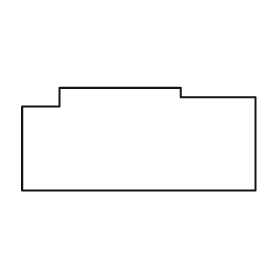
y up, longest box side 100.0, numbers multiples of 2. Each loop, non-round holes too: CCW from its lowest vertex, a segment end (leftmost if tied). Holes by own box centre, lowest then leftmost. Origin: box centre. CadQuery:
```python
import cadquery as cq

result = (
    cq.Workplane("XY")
    .moveTo(-50.0, -22.0)
    .lineTo(50.0, -22.0)
    .lineTo(50.0, 18.0)
    .lineTo(18.0, 18.0)
    .lineTo(18.0, 22.0)
    .lineTo(-34.0, 22.0)
    .lineTo(-34.0, 14.0)
    .lineTo(-50.0, 14.0)
    .close()
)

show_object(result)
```